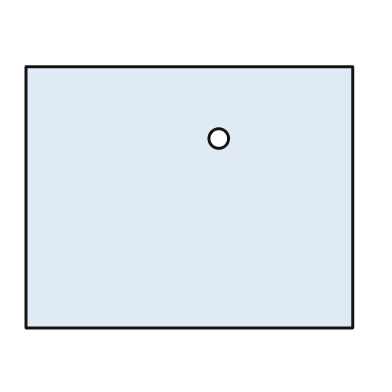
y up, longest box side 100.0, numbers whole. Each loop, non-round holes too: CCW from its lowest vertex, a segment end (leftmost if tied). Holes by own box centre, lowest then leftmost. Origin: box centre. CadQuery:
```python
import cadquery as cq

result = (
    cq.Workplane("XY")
    .moveTo(-50.0, -40.0)
    .lineTo(50.0, -40.0)
    .lineTo(50.0, 40.0)
    .lineTo(-50.0, 40.0)
    .close()
    .moveTo(9.0, 18.0)
    .circle(3.0)
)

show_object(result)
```